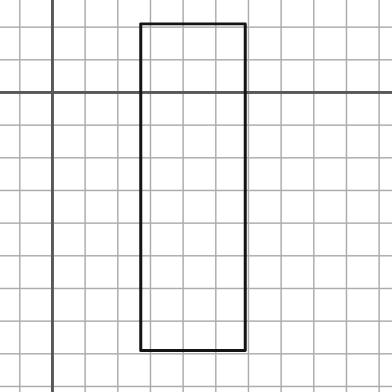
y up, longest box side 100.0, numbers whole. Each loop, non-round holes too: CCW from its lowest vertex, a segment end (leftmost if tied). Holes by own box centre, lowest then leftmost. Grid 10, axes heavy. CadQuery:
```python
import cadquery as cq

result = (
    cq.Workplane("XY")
    .moveTo(27.0, -79.0)
    .lineTo(59.0, -79.0)
    .lineTo(59.0, 21.0)
    .lineTo(27.0, 21.0)
    .close()
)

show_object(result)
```